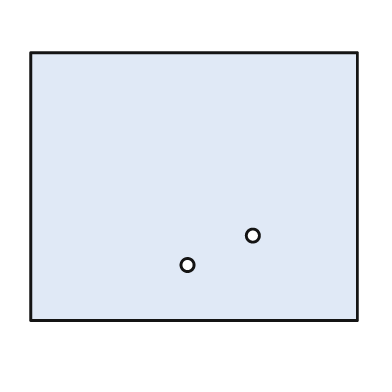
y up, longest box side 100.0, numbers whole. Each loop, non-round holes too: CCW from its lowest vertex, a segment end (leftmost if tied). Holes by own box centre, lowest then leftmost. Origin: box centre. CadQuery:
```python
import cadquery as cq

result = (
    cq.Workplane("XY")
    .moveTo(-50.0, -41.0)
    .lineTo(50.0, -41.0)
    .lineTo(50.0, 41.0)
    .lineTo(-50.0, 41.0)
    .close()
    .moveTo(-2.0, -24.0)
    .circle(2.0)
    .moveTo(18.0, -15.0)
    .circle(2.0)
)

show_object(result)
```